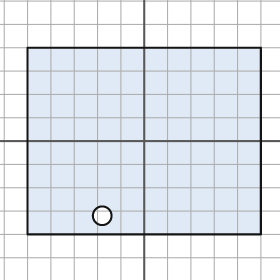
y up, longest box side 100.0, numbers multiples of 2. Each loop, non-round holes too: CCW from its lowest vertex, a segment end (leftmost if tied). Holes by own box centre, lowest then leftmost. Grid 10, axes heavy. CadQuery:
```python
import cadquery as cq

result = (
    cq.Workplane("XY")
    .moveTo(-50.0, -40.0)
    .lineTo(50.0, -40.0)
    .lineTo(50.0, 40.0)
    .lineTo(-50.0, 40.0)
    .close()
    .moveTo(-18.0, -32.0)
    .circle(4.0)
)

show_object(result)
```